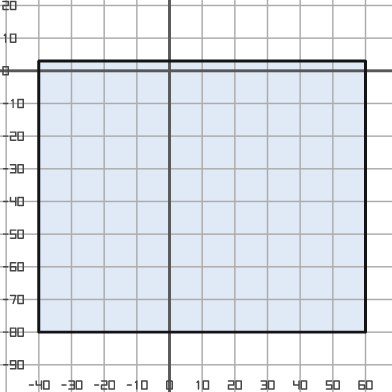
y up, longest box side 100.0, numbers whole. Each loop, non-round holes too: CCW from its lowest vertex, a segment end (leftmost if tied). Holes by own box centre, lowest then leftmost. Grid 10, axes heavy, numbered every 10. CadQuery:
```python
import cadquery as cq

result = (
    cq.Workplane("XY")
    .moveTo(-40.0, -80.0)
    .lineTo(60.0, -80.0)
    .lineTo(60.0, 3.0)
    .lineTo(-40.0, 3.0)
    .close()
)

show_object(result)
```